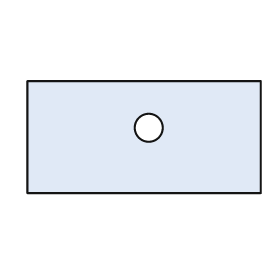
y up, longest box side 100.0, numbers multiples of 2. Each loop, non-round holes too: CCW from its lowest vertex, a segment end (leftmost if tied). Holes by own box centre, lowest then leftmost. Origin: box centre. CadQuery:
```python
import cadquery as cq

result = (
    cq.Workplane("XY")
    .moveTo(-50.0, -24.0)
    .lineTo(50.0, -24.0)
    .lineTo(50.0, 24.0)
    .lineTo(-50.0, 24.0)
    .close()
    .moveTo(2.0, 4.0)
    .circle(6.0)
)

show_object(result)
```